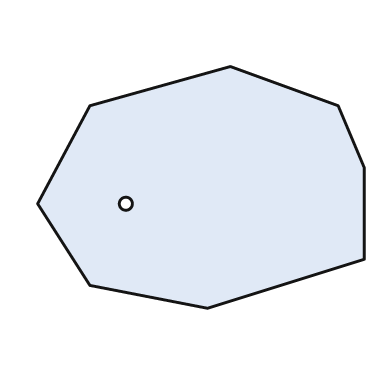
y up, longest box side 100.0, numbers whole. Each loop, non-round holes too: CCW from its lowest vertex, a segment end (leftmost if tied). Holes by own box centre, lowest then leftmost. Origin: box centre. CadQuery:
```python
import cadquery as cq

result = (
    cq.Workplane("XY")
    .moveTo(2.0, -37.0)
    .lineTo(50.0, -22.0)
    .lineTo(50.0, 6.0)
    .lineTo(42.0, 25.0)
    .lineTo(9.0, 37.0)
    .lineTo(-34.0, 25.0)
    .lineTo(-50.0, -5.0)
    .lineTo(-34.0, -30.0)
    .close()
    .moveTo(-23.0, -5.0)
    .circle(2.0)
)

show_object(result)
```